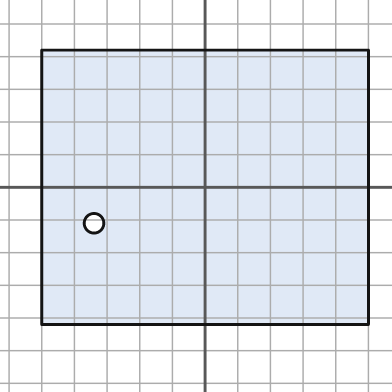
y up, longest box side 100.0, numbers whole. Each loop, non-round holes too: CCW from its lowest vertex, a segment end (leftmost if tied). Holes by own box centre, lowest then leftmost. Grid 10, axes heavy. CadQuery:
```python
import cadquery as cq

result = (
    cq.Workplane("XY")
    .moveTo(-50.0, -42.0)
    .lineTo(50.0, -42.0)
    .lineTo(50.0, 42.0)
    .lineTo(-50.0, 42.0)
    .close()
    .moveTo(-34.0, -11.0)
    .circle(3.0)
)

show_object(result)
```